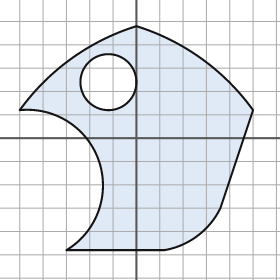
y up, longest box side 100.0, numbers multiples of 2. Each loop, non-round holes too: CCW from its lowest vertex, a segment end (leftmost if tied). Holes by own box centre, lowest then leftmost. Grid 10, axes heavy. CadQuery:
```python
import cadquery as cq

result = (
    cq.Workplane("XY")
    .moveTo(-30.0, -48.0)
    .lineTo(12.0, -48.0)
    .threePointArc((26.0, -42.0), (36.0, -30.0))
    .lineTo(50.0, 12.0)
    .threePointArc((28.0, 34.0), (0.0, 48.0))
    .threePointArc((-28.0, 34.0), (-50.0, 12.0))
    .threePointArc((-16.0, -10.0), (-30.0, -48.0))
    .close()
    .moveTo(-12.0, 24.0)
    .circle(12.0)
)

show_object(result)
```